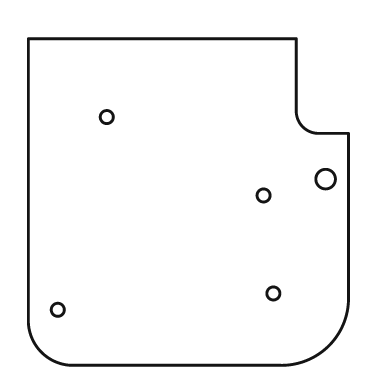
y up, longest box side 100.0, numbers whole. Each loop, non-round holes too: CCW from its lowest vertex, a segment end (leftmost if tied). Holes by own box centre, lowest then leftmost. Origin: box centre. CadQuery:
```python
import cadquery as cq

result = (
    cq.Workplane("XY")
    .moveTo(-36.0, -50.0)
    .lineTo(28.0, -50.0)
    .threePointArc((43.0, -44.0), (49.0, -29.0))
    .lineTo(49.0, 21.0)
    .lineTo(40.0, 21.0)
    .threePointArc((35.0, 23.0), (33.0, 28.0))
    .lineTo(33.0, 50.0)
    .lineTo(-49.0, 50.0)
    .lineTo(-49.0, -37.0)
    .threePointArc((-45.0, -46.0), (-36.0, -50.0))
    .close()
    .moveTo(-40.0, -33.0)
    .circle(2.0)
    .moveTo(26.0, -28.0)
    .circle(2.0)
    .moveTo(23.0, 2.0)
    .circle(2.0)
    .moveTo(42.0, 7.0)
    .circle(3.0)
    .moveTo(-25.0, 26.0)
    .circle(2.0)
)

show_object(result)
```